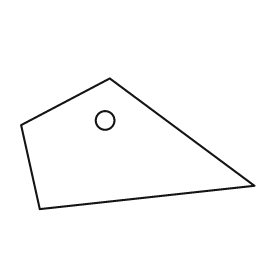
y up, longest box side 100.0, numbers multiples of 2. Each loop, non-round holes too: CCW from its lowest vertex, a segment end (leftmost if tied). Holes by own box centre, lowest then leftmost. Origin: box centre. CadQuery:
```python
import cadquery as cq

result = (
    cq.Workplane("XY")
    .moveTo(-42.0, -28.0)
    .lineTo(50.0, -18.0)
    .lineTo(-12.0, 28.0)
    .lineTo(-50.0, 8.0)
    .close()
    .moveTo(-14.0, 10.0)
    .circle(4.0)
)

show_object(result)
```